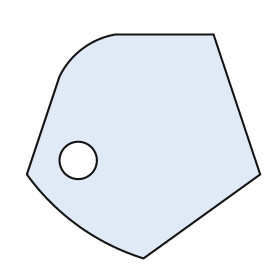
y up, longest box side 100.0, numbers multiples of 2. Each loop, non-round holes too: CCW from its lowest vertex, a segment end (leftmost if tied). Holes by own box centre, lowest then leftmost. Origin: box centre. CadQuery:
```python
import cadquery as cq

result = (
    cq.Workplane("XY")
    .moveTo(0.0, -48.0)
    .lineTo(50.0, -12.0)
    .lineTo(30.0, 48.0)
    .lineTo(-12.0, 48.0)
    .threePointArc((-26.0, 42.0), (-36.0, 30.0))
    .lineTo(-50.0, -12.0)
    .threePointArc((-28.0, -34.0), (0.0, -48.0))
    .close()
    .moveTo(-28.0, -6.0)
    .circle(8.0)
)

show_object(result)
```